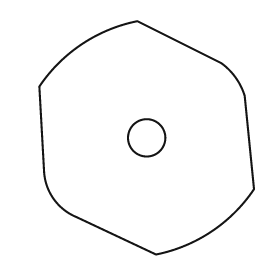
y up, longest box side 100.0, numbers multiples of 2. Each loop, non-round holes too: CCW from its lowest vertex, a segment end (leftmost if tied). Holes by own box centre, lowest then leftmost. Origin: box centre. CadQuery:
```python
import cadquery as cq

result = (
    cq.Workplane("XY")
    .moveTo(4.0, -50.0)
    .threePointArc((28.0, -40.0), (46.0, -22.0))
    .lineTo(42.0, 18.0)
    .threePointArc((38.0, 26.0), (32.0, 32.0))
    .lineTo(-4.0, 50.0)
    .threePointArc((-28.0, 40.0), (-46.0, 22.0))
    .lineTo(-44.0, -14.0)
    .threePointArc((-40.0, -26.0), (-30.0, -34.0))
    .close()
    .moveTo(0.0, 0.0)
    .circle(8.0)
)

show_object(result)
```